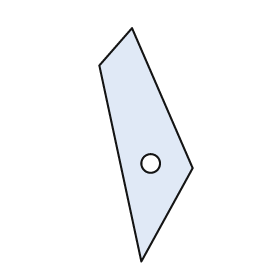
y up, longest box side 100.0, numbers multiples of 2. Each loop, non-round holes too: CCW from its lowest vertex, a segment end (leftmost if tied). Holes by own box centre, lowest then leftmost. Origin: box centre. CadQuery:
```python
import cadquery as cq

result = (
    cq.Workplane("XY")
    .moveTo(-2.0, -50.0)
    .lineTo(20.0, -10.0)
    .lineTo(-6.0, 50.0)
    .lineTo(-20.0, 34.0)
    .close()
    .moveTo(2.0, -8.0)
    .circle(4.0)
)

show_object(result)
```